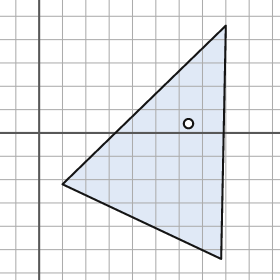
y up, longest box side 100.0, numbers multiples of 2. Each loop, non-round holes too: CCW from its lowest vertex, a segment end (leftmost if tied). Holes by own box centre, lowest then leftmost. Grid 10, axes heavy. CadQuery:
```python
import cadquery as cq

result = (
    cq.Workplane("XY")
    .moveTo(78.0, -54.0)
    .lineTo(80.0, 46.0)
    .lineTo(10.0, -22.0)
    .close()
    .moveTo(64.0, 4.0)
    .circle(2.0)
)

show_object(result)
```